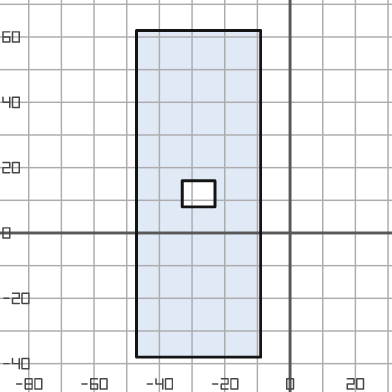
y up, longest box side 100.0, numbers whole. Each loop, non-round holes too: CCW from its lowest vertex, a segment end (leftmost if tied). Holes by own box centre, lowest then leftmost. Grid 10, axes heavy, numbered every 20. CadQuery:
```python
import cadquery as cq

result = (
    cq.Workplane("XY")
    .moveTo(-47.0, -38.0)
    .lineTo(-9.0, -38.0)
    .lineTo(-9.0, 62.0)
    .lineTo(-47.0, 62.0)
    .close()
    .moveTo(-33.0, 8.0)
    .lineTo(-23.0, 8.0)
    .lineTo(-23.0, 16.0)
    .lineTo(-33.0, 16.0)
    .close()
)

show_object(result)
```